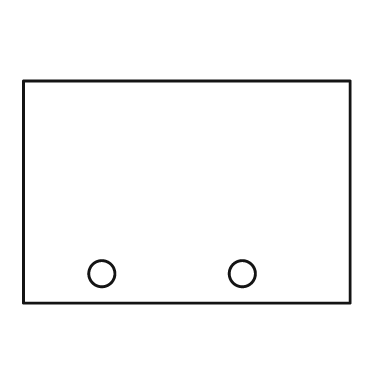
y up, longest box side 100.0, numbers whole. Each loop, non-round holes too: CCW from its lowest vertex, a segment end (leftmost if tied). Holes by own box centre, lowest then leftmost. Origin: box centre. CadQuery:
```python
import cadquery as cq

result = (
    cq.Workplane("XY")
    .moveTo(-50.0, -34.0)
    .lineTo(50.0, -34.0)
    .lineTo(50.0, 34.0)
    .lineTo(-50.0, 34.0)
    .close()
    .moveTo(-26.0, -25.0)
    .circle(4.0)
    .moveTo(17.0, -25.0)
    .circle(4.0)
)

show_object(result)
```